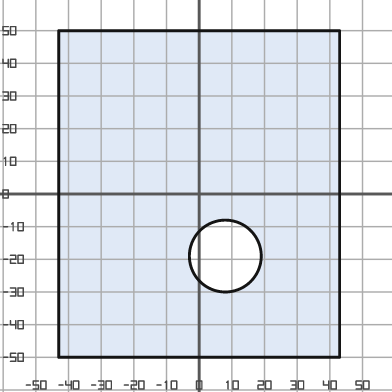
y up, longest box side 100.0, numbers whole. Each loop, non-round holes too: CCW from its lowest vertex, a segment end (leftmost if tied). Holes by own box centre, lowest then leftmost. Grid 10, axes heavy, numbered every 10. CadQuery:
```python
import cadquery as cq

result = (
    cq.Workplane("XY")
    .moveTo(-43.0, -50.0)
    .lineTo(43.0, -50.0)
    .lineTo(43.0, 50.0)
    .lineTo(-43.0, 50.0)
    .close()
    .moveTo(8.0, -19.0)
    .circle(11.0)
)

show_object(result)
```